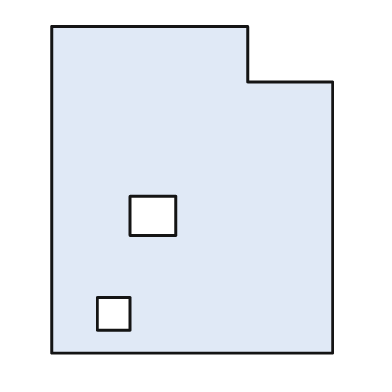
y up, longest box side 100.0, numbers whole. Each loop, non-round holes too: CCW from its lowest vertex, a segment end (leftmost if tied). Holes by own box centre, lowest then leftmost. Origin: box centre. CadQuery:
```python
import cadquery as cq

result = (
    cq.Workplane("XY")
    .moveTo(-43.0, -50.0)
    .lineTo(43.0, -50.0)
    .lineTo(43.0, 33.0)
    .lineTo(17.0, 33.0)
    .lineTo(17.0, 50.0)
    .lineTo(-43.0, 50.0)
    .close()
    .moveTo(-29.0, -43.0)
    .lineTo(-19.0, -43.0)
    .lineTo(-19.0, -33.0)
    .lineTo(-29.0, -33.0)
    .close()
    .moveTo(-19.0, -14.0)
    .lineTo(-5.0, -14.0)
    .lineTo(-5.0, -2.0)
    .lineTo(-19.0, -2.0)
    .close()
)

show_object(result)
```